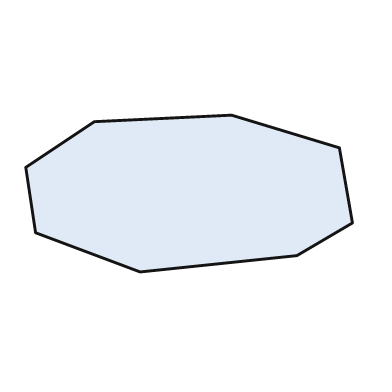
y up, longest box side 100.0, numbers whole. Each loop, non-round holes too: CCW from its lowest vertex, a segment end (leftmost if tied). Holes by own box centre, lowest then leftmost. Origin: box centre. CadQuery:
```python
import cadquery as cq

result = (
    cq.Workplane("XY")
    .moveTo(-15.0, -24.0)
    .lineTo(33.0, -19.0)
    .lineTo(50.0, -9.0)
    .lineTo(46.0, 14.0)
    .lineTo(13.0, 24.0)
    .lineTo(-29.0, 22.0)
    .lineTo(-50.0, 8.0)
    .lineTo(-47.0, -12.0)
    .close()
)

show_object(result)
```